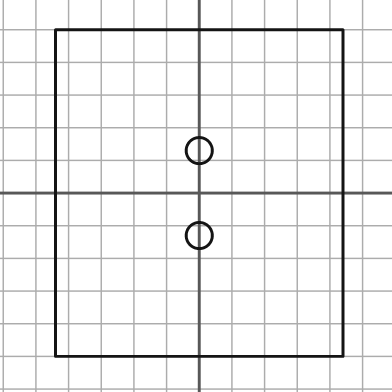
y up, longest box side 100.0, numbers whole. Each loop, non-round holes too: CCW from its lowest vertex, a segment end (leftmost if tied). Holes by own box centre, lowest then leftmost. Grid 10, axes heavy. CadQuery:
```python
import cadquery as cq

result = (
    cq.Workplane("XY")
    .moveTo(-44.0, -50.0)
    .lineTo(44.0, -50.0)
    .lineTo(44.0, 50.0)
    .lineTo(-44.0, 50.0)
    .close()
    .moveTo(0.0, -13.0)
    .circle(4.0)
    .moveTo(0.0, 13.0)
    .circle(4.0)
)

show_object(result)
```